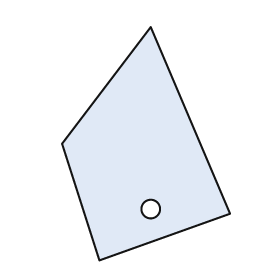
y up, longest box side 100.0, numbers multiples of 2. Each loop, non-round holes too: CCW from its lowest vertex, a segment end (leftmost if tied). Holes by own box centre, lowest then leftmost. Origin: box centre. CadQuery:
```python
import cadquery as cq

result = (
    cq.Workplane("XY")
    .moveTo(-20.0, -50.0)
    .lineTo(36.0, -30.0)
    .lineTo(2.0, 50.0)
    .lineTo(-36.0, 0.0)
    .close()
    .moveTo(2.0, -28.0)
    .circle(4.0)
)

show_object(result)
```